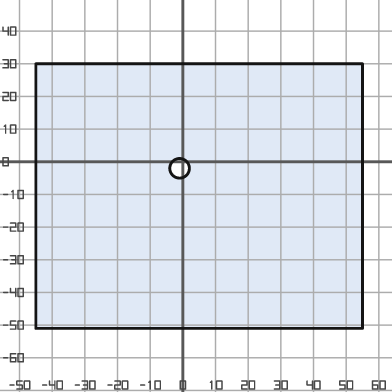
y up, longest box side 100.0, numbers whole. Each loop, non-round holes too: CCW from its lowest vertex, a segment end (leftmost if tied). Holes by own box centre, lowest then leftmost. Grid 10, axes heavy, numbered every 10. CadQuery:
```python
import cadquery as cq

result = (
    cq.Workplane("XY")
    .moveTo(-45.0, -51.0)
    .lineTo(55.0, -51.0)
    .lineTo(55.0, 30.0)
    .lineTo(-45.0, 30.0)
    .close()
    .moveTo(-1.0, -2.0)
    .circle(3.0)
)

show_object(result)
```